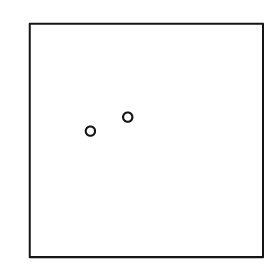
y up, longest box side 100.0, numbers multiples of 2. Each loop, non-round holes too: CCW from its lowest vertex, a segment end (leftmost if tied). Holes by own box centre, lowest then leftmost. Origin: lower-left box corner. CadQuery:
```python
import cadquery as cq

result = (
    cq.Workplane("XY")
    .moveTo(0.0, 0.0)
    .lineTo(100.0, 0.0)
    .lineTo(100.0, 100.0)
    .lineTo(0.0, 100.0)
    .close()
    .moveTo(26.0, 54.0)
    .circle(2.0)
    .moveTo(42.0, 60.0)
    .circle(2.0)
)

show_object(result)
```